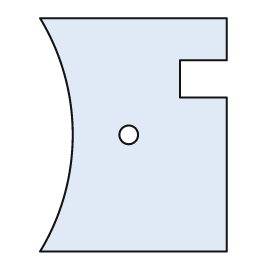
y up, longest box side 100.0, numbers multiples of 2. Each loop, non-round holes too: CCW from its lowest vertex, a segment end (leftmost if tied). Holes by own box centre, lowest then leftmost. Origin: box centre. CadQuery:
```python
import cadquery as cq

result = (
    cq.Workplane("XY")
    .moveTo(-40.0, -50.0)
    .lineTo(40.0, -50.0)
    .lineTo(40.0, 16.0)
    .lineTo(20.0, 16.0)
    .lineTo(20.0, 32.0)
    .lineTo(40.0, 32.0)
    .lineTo(40.0, 50.0)
    .lineTo(-40.0, 50.0)
    .threePointArc((-26.0, 0.0), (-40.0, -50.0))
    .close()
    .moveTo(-2.0, 0.0)
    .circle(4.0)
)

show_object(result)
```